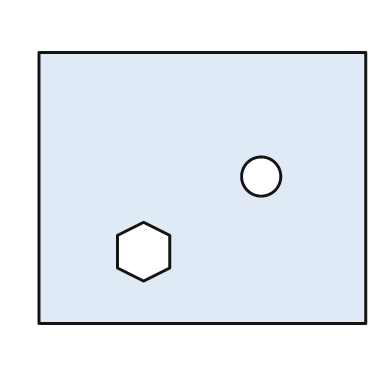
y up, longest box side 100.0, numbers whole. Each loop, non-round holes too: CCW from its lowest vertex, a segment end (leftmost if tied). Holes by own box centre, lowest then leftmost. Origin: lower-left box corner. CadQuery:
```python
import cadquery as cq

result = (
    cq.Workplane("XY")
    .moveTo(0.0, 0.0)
    .lineTo(100.0, 0.0)
    .lineTo(100.0, 83.0)
    .lineTo(0.0, 83.0)
    .close()
    .moveTo(32.0, 13.0)
    .lineTo(40.0, 17.0)
    .lineTo(40.0, 27.0)
    .lineTo(32.0, 31.0)
    .lineTo(24.0, 27.0)
    .lineTo(24.0, 17.0)
    .close()
    .moveTo(68.0, 45.0)
    .circle(6.0)
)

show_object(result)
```